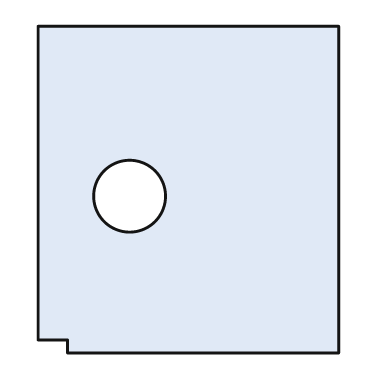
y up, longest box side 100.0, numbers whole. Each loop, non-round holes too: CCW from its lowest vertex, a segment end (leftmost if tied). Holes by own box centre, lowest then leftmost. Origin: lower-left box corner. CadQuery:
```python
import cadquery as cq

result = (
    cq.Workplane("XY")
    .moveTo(9.0, 0.0)
    .lineTo(92.0, 0.0)
    .lineTo(92.0, 100.0)
    .lineTo(0.0, 100.0)
    .lineTo(0.0, 4.0)
    .lineTo(9.0, 4.0)
    .close()
    .moveTo(28.0, 48.0)
    .circle(11.0)
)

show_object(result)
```